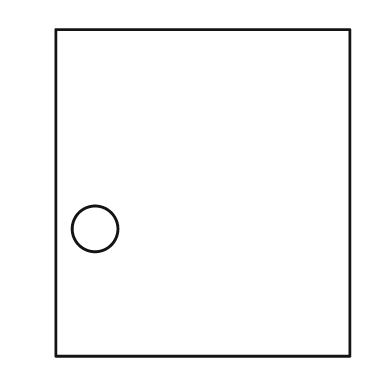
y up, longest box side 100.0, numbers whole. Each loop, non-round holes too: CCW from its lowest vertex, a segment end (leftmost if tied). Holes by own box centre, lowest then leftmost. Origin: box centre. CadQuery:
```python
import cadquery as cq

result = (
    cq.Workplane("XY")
    .moveTo(-45.0, -50.0)
    .lineTo(45.0, -50.0)
    .lineTo(45.0, 50.0)
    .lineTo(-45.0, 50.0)
    .close()
    .moveTo(-33.0, -11.0)
    .circle(7.0)
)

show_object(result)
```